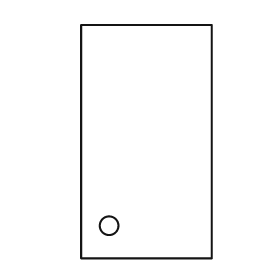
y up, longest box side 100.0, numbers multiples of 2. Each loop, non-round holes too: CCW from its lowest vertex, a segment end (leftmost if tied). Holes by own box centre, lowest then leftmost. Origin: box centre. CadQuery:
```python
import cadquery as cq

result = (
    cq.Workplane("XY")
    .moveTo(-28.0, -50.0)
    .lineTo(28.0, -50.0)
    .lineTo(28.0, 50.0)
    .lineTo(-28.0, 50.0)
    .close()
    .moveTo(-16.0, -36.0)
    .circle(4.0)
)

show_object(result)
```